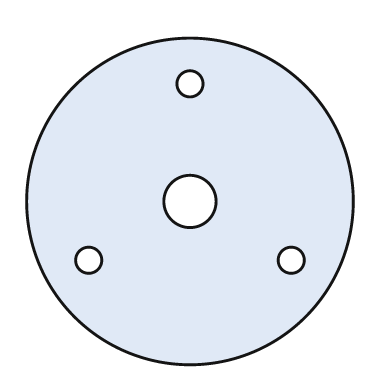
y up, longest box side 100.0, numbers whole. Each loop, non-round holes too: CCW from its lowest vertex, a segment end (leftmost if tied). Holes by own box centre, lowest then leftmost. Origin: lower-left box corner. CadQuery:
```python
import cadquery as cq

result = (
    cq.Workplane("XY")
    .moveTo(50.0, 50.0)
    .circle(50.0)
    .moveTo(19.0, 32.0)
    .circle(4.0)
    .moveTo(81.0, 32.0)
    .circle(4.0)
    .moveTo(50.0, 50.0)
    .circle(8.0)
    .moveTo(50.0, 86.0)
    .circle(4.0)
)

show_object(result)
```